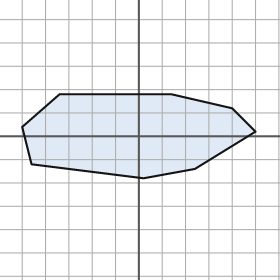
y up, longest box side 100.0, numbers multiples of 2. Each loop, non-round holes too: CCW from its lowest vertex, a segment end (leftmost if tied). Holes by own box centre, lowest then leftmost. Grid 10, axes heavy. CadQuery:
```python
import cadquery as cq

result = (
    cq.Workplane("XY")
    .moveTo(2.0, -18.0)
    .lineTo(24.0, -14.0)
    .lineTo(50.0, 2.0)
    .lineTo(40.0, 12.0)
    .lineTo(14.0, 18.0)
    .lineTo(-34.0, 18.0)
    .lineTo(-50.0, 4.0)
    .lineTo(-46.0, -12.0)
    .close()
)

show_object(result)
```